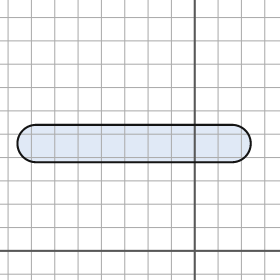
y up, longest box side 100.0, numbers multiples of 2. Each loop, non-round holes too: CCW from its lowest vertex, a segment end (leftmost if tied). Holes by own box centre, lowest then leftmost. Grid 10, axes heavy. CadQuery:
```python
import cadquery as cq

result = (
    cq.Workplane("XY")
    .moveTo(-68.0, 38.0)
    .lineTo(16.0, 38.0)
    .threePointArc((24.0, 46.0), (16.0, 54.0))
    .lineTo(-68.0, 54.0)
    .threePointArc((-76.0, 46.0), (-68.0, 38.0))
    .close()
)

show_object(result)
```